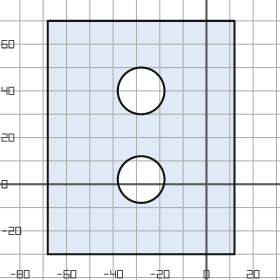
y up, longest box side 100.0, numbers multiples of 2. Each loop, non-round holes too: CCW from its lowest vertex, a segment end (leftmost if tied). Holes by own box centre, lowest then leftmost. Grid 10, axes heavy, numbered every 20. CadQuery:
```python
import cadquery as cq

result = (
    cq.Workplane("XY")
    .moveTo(-68.0, -30.0)
    .lineTo(12.0, -30.0)
    .lineTo(12.0, 70.0)
    .lineTo(-68.0, 70.0)
    .close()
    .moveTo(-28.0, 2.0)
    .circle(10.0)
    .moveTo(-28.0, 40.0)
    .circle(10.0)
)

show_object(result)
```